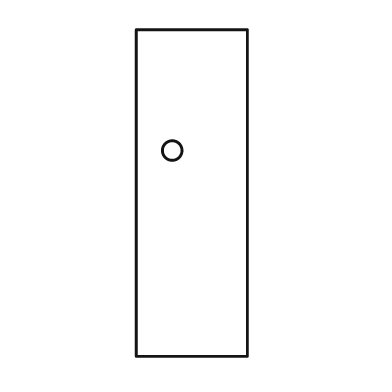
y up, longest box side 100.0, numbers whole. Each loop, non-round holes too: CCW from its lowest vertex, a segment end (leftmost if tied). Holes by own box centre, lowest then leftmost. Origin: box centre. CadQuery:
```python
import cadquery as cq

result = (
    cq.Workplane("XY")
    .moveTo(-17.0, -50.0)
    .lineTo(17.0, -50.0)
    .lineTo(17.0, 50.0)
    .lineTo(-17.0, 50.0)
    .close()
    .moveTo(-6.0, 13.0)
    .circle(3.0)
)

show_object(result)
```